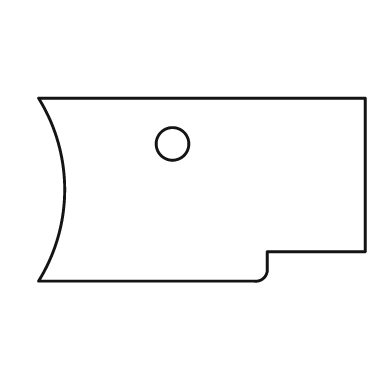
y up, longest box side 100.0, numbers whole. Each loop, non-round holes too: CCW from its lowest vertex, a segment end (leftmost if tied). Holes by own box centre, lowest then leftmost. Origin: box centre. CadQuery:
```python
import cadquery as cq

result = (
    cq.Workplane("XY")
    .moveTo(-50.0, -28.0)
    .lineTo(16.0, -28.0)
    .threePointArc((19.0, -27.0), (20.0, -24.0))
    .lineTo(20.0, -19.0)
    .lineTo(50.0, -19.0)
    .lineTo(50.0, 28.0)
    .lineTo(-50.0, 28.0)
    .threePointArc((-42.0, 0.0), (-50.0, -28.0))
    .close()
    .moveTo(-9.0, 14.0)
    .circle(5.0)
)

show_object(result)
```